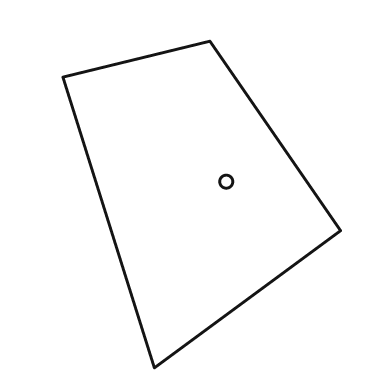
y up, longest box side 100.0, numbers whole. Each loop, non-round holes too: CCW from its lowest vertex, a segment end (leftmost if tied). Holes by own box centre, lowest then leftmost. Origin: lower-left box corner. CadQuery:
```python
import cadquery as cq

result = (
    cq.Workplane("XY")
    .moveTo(28.0, 0.0)
    .lineTo(85.0, 42.0)
    .lineTo(45.0, 100.0)
    .lineTo(0.0, 89.0)
    .close()
    .moveTo(50.0, 57.0)
    .circle(2.0)
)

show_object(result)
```